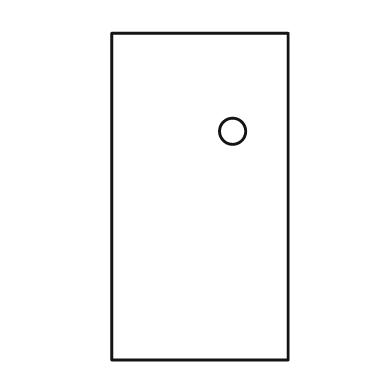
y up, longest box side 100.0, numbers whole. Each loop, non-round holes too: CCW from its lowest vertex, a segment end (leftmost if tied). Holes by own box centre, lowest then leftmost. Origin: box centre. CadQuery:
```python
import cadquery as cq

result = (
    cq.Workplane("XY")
    .moveTo(-27.0, -50.0)
    .lineTo(27.0, -50.0)
    .lineTo(27.0, 50.0)
    .lineTo(-27.0, 50.0)
    .close()
    .moveTo(10.0, 20.0)
    .circle(4.0)
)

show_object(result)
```